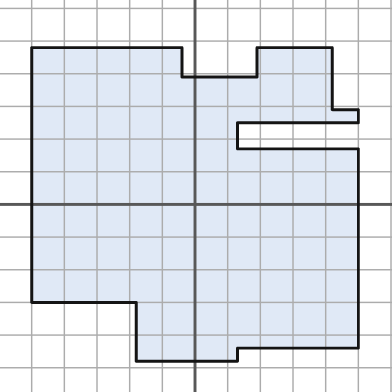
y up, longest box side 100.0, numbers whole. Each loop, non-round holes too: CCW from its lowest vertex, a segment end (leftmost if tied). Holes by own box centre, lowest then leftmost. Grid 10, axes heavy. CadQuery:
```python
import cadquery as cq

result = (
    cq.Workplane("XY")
    .moveTo(-18.0, -48.0)
    .lineTo(13.0, -48.0)
    .lineTo(13.0, -44.0)
    .lineTo(50.0, -44.0)
    .lineTo(50.0, 17.0)
    .lineTo(13.0, 17.0)
    .lineTo(13.0, 25.0)
    .lineTo(50.0, 25.0)
    .lineTo(50.0, 29.0)
    .lineTo(42.0, 29.0)
    .lineTo(42.0, 48.0)
    .lineTo(19.0, 48.0)
    .lineTo(19.0, 39.0)
    .lineTo(-4.0, 39.0)
    .lineTo(-4.0, 48.0)
    .lineTo(-50.0, 48.0)
    .lineTo(-50.0, -30.0)
    .lineTo(-18.0, -30.0)
    .close()
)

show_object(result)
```